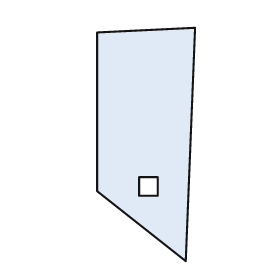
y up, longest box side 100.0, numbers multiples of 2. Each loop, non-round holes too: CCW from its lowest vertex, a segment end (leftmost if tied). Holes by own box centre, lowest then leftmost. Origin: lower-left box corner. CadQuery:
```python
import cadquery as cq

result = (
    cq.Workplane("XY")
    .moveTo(38.0, 0.0)
    .lineTo(42.0, 100.0)
    .lineTo(0.0, 98.0)
    .lineTo(0.0, 30.0)
    .close()
    .moveTo(18.0, 28.0)
    .lineTo(26.0, 28.0)
    .lineTo(26.0, 36.0)
    .lineTo(18.0, 36.0)
    .close()
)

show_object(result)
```